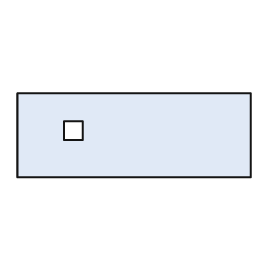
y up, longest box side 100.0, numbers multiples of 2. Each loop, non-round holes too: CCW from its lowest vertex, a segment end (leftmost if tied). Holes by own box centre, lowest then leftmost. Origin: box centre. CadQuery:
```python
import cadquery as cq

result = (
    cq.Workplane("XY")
    .moveTo(-50.0, -18.0)
    .lineTo(50.0, -18.0)
    .lineTo(50.0, 18.0)
    .lineTo(-50.0, 18.0)
    .close()
    .moveTo(-30.0, -2.0)
    .lineTo(-22.0, -2.0)
    .lineTo(-22.0, 6.0)
    .lineTo(-30.0, 6.0)
    .close()
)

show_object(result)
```